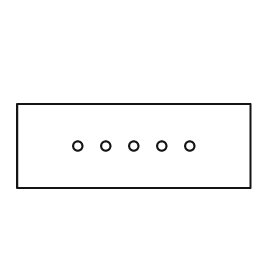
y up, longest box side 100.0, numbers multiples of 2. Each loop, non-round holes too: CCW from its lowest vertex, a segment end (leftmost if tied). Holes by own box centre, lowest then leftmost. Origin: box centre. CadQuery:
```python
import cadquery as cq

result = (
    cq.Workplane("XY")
    .moveTo(-50.0, -18.0)
    .lineTo(50.0, -18.0)
    .lineTo(50.0, 18.0)
    .lineTo(-50.0, 18.0)
    .close()
    .moveTo(-24.0, 0.0)
    .circle(2.0)
    .moveTo(-12.0, 0.0)
    .circle(2.0)
    .moveTo(0.0, 0.0)
    .circle(2.0)
    .moveTo(12.0, 0.0)
    .circle(2.0)
    .moveTo(24.0, 0.0)
    .circle(2.0)
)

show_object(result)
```